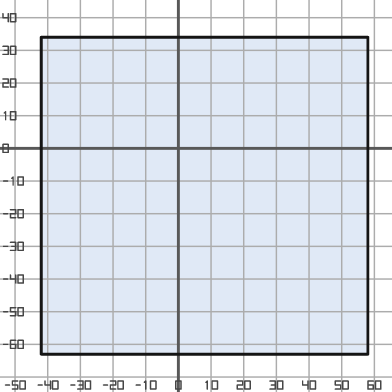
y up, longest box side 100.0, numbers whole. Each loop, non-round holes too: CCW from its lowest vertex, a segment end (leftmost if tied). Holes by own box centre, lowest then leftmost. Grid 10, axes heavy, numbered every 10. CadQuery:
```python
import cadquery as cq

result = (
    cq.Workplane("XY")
    .moveTo(-42.0, -63.0)
    .lineTo(58.0, -63.0)
    .lineTo(58.0, 34.0)
    .lineTo(-42.0, 34.0)
    .close()
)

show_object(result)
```